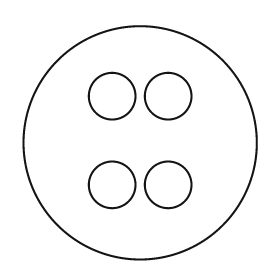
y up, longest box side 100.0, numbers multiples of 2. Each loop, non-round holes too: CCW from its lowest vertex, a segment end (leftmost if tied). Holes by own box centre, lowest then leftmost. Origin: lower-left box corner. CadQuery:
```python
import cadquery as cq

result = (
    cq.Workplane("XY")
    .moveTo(50.0, 50.0)
    .circle(50.0)
    .moveTo(38.0, 32.0)
    .circle(10.0)
    .moveTo(62.0, 32.0)
    .circle(10.0)
    .moveTo(38.0, 70.0)
    .circle(10.0)
    .moveTo(62.0, 70.0)
    .circle(10.0)
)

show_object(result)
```